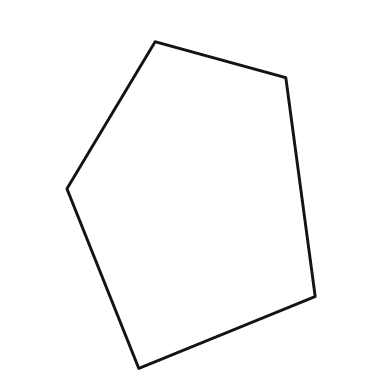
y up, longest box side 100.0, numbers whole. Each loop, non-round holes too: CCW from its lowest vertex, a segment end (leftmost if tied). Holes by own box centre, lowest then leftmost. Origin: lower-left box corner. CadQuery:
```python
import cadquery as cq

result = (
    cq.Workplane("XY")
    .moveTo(22.0, 0.0)
    .lineTo(76.0, 22.0)
    .lineTo(67.0, 89.0)
    .lineTo(27.0, 100.0)
    .lineTo(0.0, 55.0)
    .close()
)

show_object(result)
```